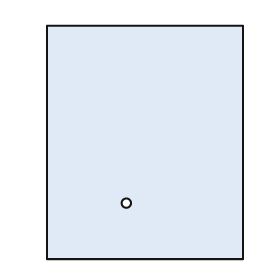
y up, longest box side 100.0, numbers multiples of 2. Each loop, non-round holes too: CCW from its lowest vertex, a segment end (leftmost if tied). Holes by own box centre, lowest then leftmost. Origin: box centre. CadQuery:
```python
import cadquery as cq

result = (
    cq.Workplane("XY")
    .moveTo(-42.0, -50.0)
    .lineTo(42.0, -50.0)
    .lineTo(42.0, 50.0)
    .lineTo(-42.0, 50.0)
    .close()
    .moveTo(-8.0, -26.0)
    .circle(2.0)
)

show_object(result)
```